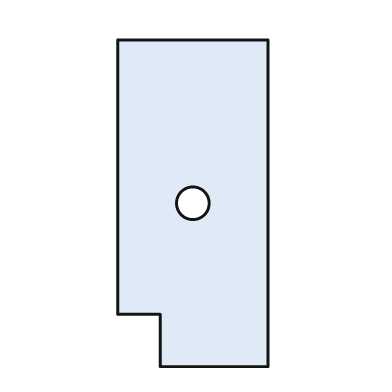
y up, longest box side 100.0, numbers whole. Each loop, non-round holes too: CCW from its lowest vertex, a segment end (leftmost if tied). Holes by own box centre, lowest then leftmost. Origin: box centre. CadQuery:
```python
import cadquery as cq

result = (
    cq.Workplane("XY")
    .moveTo(-10.0, -50.0)
    .lineTo(23.0, -50.0)
    .lineTo(23.0, 50.0)
    .lineTo(-23.0, 50.0)
    .lineTo(-23.0, -34.0)
    .lineTo(-10.0, -34.0)
    .close()
    .moveTo(0.0, 0.0)
    .circle(5.0)
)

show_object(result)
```